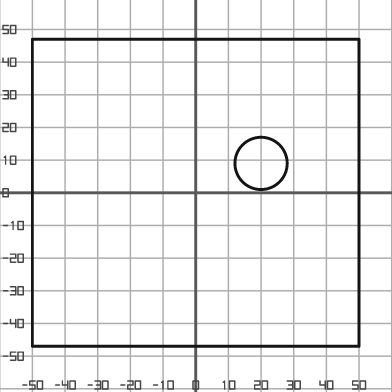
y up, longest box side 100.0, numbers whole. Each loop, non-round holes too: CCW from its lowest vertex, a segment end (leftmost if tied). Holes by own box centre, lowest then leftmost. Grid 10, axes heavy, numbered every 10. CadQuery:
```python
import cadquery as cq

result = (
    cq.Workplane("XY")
    .moveTo(-50.0, -47.0)
    .lineTo(50.0, -47.0)
    .lineTo(50.0, 47.0)
    .lineTo(-50.0, 47.0)
    .close()
    .moveTo(20.0, 9.0)
    .circle(8.0)
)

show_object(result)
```